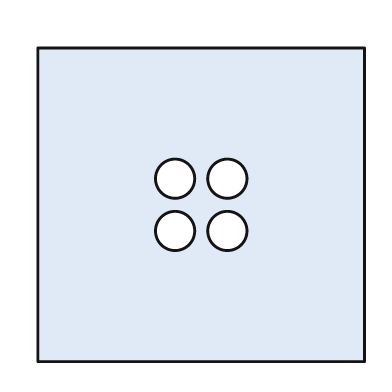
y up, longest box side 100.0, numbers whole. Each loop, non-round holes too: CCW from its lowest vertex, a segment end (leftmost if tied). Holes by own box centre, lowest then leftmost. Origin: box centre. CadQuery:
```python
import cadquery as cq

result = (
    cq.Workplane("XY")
    .moveTo(-50.0, -48.0)
    .lineTo(50.0, -48.0)
    .lineTo(50.0, 48.0)
    .lineTo(-50.0, 48.0)
    .close()
    .moveTo(-8.0, -8.0)
    .circle(6.0)
    .moveTo(8.0, -8.0)
    .circle(6.0)
    .moveTo(-8.0, 8.0)
    .circle(6.0)
    .moveTo(8.0, 8.0)
    .circle(6.0)
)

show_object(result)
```